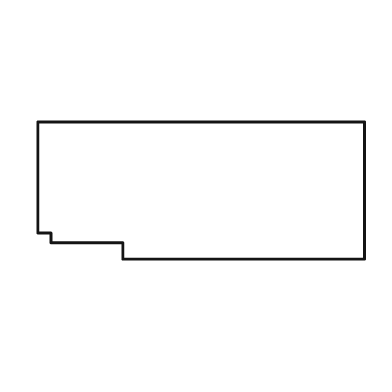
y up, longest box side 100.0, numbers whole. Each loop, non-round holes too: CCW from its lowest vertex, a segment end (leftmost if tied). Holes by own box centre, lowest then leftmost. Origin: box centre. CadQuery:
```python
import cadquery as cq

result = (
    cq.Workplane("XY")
    .moveTo(-24.0, -21.0)
    .lineTo(50.0, -21.0)
    .lineTo(50.0, 21.0)
    .lineTo(-50.0, 21.0)
    .lineTo(-50.0, -13.0)
    .lineTo(-46.0, -13.0)
    .lineTo(-46.0, -16.0)
    .lineTo(-24.0, -16.0)
    .close()
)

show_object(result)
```